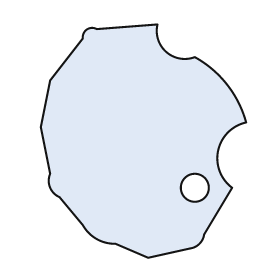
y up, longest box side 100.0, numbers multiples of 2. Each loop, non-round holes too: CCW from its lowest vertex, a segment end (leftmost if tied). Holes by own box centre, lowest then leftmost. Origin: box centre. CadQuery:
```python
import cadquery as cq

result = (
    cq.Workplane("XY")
    .moveTo(2.0, -50.0)
    .lineTo(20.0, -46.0)
    .threePointArc((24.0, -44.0), (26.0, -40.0))
    .lineTo(38.0, -20.0)
    .threePointArc((32.0, -4.0), (44.0, 8.0))
    .threePointArc((36.0, 24.0), (22.0, 36.0))
    .threePointArc((10.0, 38.0), (6.0, 50.0))
    .lineTo(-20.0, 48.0)
    .threePointArc((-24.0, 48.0), (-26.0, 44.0))
    .lineTo(-40.0, 26.0)
    .lineTo(-44.0, 6.0)
    .lineTo(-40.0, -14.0)
    .threePointArc((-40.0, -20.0), (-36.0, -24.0))
    .lineTo(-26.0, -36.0)
    .threePointArc((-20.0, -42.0), (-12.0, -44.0))
    .close()
    .moveTo(22.0, -20.0)
    .circle(6.0)
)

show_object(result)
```